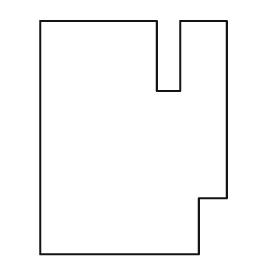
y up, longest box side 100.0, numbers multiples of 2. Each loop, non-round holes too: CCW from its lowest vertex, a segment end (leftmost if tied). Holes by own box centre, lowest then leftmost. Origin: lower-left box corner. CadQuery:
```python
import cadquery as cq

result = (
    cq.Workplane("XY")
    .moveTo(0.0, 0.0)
    .lineTo(68.0, 0.0)
    .lineTo(68.0, 24.0)
    .lineTo(80.0, 24.0)
    .lineTo(80.0, 100.0)
    .lineTo(60.0, 100.0)
    .lineTo(60.0, 70.0)
    .lineTo(50.0, 70.0)
    .lineTo(50.0, 100.0)
    .lineTo(0.0, 100.0)
    .close()
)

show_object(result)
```